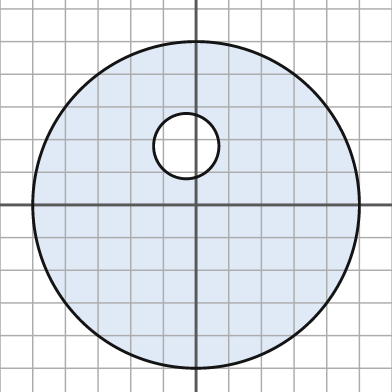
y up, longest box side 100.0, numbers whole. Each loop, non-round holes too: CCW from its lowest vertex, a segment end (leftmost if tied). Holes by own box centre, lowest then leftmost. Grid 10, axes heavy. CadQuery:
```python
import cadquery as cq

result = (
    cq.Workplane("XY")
    .moveTo(0.0, 0.0)
    .circle(50.0)
    .moveTo(-3.0, 18.0)
    .circle(10.0)
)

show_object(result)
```